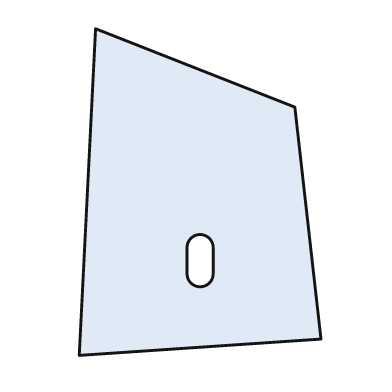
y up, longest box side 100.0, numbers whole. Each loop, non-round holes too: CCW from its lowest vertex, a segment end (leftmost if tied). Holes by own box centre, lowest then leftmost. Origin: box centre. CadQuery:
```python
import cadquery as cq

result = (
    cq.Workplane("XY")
    .moveTo(-37.0, -50.0)
    .lineTo(37.0, -45.0)
    .lineTo(29.0, 26.0)
    .lineTo(-32.0, 50.0)
    .close()
    .moveTo(-4.0, -25.0)
    .threePointArc((0.0, -29.0), (4.0, -25.0))
    .lineTo(4.0, -17.0)
    .threePointArc((0.0, -13.0), (-4.0, -17.0))
    .close()
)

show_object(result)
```